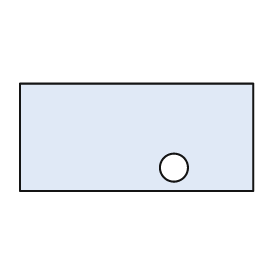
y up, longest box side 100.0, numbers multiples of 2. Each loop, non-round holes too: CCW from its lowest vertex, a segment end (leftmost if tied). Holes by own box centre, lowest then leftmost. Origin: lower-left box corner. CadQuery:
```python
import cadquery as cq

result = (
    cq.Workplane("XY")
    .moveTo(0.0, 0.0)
    .lineTo(100.0, 0.0)
    .lineTo(100.0, 46.0)
    .lineTo(0.0, 46.0)
    .close()
    .moveTo(66.0, 10.0)
    .circle(6.0)
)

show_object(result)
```